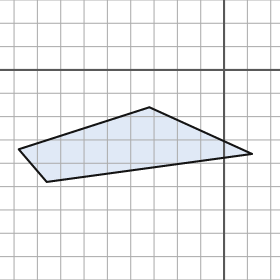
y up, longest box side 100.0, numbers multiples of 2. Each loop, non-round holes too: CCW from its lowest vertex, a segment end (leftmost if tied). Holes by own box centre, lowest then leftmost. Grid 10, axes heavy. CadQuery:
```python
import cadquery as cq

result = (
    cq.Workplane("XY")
    .moveTo(-76.0, -48.0)
    .lineTo(12.0, -36.0)
    .lineTo(-32.0, -16.0)
    .lineTo(-88.0, -34.0)
    .close()
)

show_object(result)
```